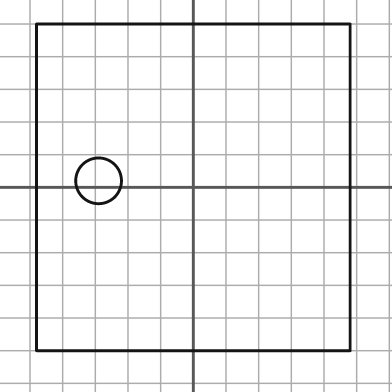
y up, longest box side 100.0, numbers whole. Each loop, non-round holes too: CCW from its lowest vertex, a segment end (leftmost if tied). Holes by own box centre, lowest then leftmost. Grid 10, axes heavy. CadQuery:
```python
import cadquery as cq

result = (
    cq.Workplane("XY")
    .moveTo(-48.0, -50.0)
    .lineTo(48.0, -50.0)
    .lineTo(48.0, 50.0)
    .lineTo(-48.0, 50.0)
    .close()
    .moveTo(-29.0, 2.0)
    .circle(7.0)
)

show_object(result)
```